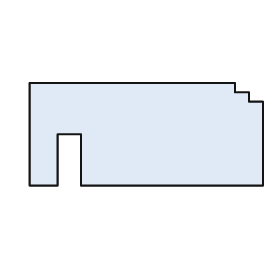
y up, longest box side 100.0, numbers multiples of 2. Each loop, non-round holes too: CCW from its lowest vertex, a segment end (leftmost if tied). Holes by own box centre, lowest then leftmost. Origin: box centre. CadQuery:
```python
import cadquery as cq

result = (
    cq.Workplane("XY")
    .moveTo(-50.0, -22.0)
    .lineTo(-38.0, -22.0)
    .lineTo(-38.0, 0.0)
    .lineTo(-28.0, 0.0)
    .lineTo(-28.0, -22.0)
    .lineTo(50.0, -22.0)
    .lineTo(50.0, 14.0)
    .lineTo(44.0, 14.0)
    .lineTo(44.0, 18.0)
    .lineTo(38.0, 18.0)
    .lineTo(38.0, 22.0)
    .lineTo(-50.0, 22.0)
    .close()
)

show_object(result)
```